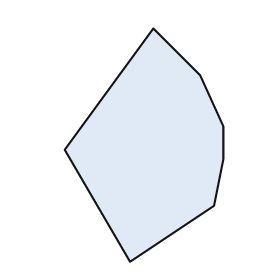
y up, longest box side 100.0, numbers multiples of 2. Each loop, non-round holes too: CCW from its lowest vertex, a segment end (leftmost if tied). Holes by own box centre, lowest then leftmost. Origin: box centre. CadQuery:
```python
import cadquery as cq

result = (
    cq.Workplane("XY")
    .moveTo(-6.0, -50.0)
    .lineTo(30.0, -26.0)
    .lineTo(34.0, -6.0)
    .lineTo(34.0, 8.0)
    .lineTo(24.0, 30.0)
    .lineTo(4.0, 50.0)
    .lineTo(-34.0, -2.0)
    .close()
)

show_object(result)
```